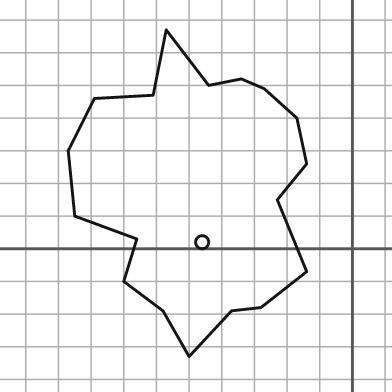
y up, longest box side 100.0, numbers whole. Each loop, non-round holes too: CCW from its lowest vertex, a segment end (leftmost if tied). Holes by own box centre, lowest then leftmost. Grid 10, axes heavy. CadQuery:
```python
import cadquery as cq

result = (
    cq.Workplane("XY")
    .moveTo(-50.0, -33.0)
    .lineTo(-37.0, -19.0)
    .lineTo(-28.0, -18.0)
    .lineTo(-14.0, -7.0)
    .lineTo(-23.0, 15.0)
    .lineTo(-14.0, 26.0)
    .lineTo(-17.0, 40.0)
    .lineTo(-27.0, 49.0)
    .lineTo(-34.0, 52.0)
    .lineTo(-44.0, 50.0)
    .lineTo(-57.0, 67.0)
    .lineTo(-61.0, 47.0)
    .lineTo(-79.0, 46.0)
    .lineTo(-87.0, 30.0)
    .lineTo(-85.0, 10.0)
    .lineTo(-66.0, 3.0)
    .lineTo(-70.0, -10.0)
    .lineTo(-58.0, -19.0)
    .close()
    .moveTo(-46.0, 2.0)
    .circle(2.0)
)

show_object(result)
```